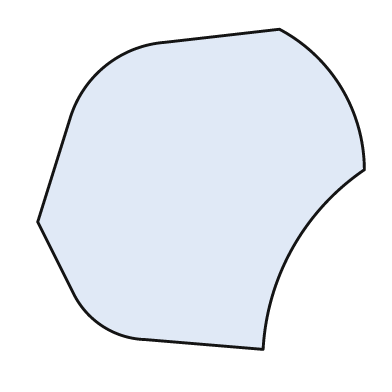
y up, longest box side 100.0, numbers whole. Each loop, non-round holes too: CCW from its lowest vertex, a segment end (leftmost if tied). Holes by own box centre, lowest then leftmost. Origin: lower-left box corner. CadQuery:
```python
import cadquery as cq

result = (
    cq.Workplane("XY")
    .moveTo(69.0, 0.0)
    .threePointArc((78.0, 31.0), (100.0, 55.0))
    .threePointArc((93.0, 80.0), (74.0, 98.0))
    .lineTo(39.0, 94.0)
    .threePointArc((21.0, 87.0), (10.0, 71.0))
    .lineTo(0.0, 39.0)
    .lineTo(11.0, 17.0)
    .threePointArc((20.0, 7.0), (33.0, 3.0))
    .close()
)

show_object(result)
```